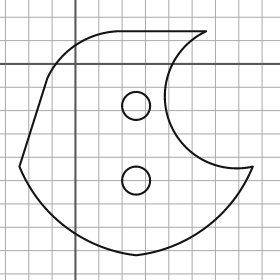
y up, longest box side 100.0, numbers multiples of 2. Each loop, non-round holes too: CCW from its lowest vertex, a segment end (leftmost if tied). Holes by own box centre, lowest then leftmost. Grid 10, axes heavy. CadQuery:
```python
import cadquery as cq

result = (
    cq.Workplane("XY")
    .moveTo(26.0, -82.0)
    .threePointArc((56.0, -70.0), (76.0, -44.0))
    .threePointArc((40.0, -24.0), (56.0, 14.0))
    .lineTo(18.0, 14.0)
    .threePointArc((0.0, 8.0), (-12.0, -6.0))
    .lineTo(-24.0, -44.0)
    .threePointArc((-4.0, -70.0), (26.0, -82.0))
    .close()
    .moveTo(26.0, -50.0)
    .circle(6.0)
    .moveTo(26.0, -18.0)
    .circle(6.0)
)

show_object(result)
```